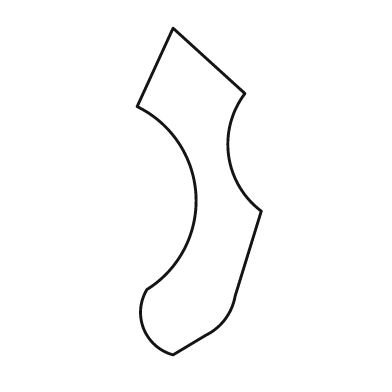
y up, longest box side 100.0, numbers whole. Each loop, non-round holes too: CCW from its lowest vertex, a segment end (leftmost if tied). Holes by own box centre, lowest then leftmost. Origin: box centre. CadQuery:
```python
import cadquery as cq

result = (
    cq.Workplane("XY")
    .moveTo(-8.0, -50.0)
    .lineTo(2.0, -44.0)
    .threePointArc((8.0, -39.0), (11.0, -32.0))
    .lineTo(19.0, -6.0)
    .threePointArc((9.0, 11.0), (14.0, 30.0))
    .lineTo(-8.0, 50.0)
    .lineTo(-19.0, 26.0)
    .threePointArc((-1.0, -1.0), (-16.0, -30.0))
    .threePointArc((-17.0, -42.0), (-8.0, -50.0))
    .close()
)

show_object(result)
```